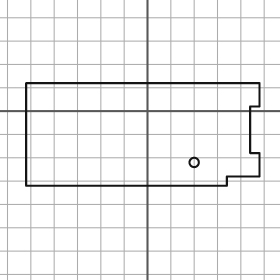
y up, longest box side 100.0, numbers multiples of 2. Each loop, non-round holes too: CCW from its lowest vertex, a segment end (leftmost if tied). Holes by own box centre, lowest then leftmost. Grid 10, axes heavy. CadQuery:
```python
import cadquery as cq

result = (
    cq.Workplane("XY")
    .moveTo(-52.0, -32.0)
    .lineTo(34.0, -32.0)
    .lineTo(34.0, -28.0)
    .lineTo(48.0, -28.0)
    .lineTo(48.0, -18.0)
    .lineTo(44.0, -18.0)
    .lineTo(44.0, 2.0)
    .lineTo(48.0, 2.0)
    .lineTo(48.0, 12.0)
    .lineTo(-52.0, 12.0)
    .close()
    .moveTo(20.0, -22.0)
    .circle(2.0)
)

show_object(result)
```